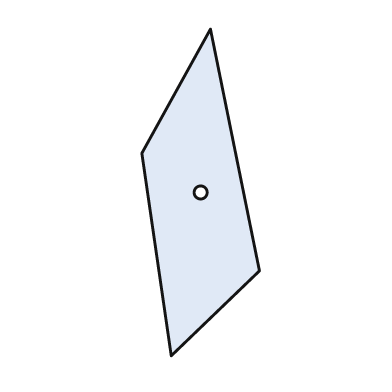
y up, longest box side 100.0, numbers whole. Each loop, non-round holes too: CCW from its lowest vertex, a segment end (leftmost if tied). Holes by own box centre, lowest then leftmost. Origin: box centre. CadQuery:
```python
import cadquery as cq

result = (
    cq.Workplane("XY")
    .moveTo(-9.0, -50.0)
    .lineTo(18.0, -24.0)
    .lineTo(3.0, 50.0)
    .lineTo(-18.0, 12.0)
    .close()
    .moveTo(0.0, 0.0)
    .circle(2.0)
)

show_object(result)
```